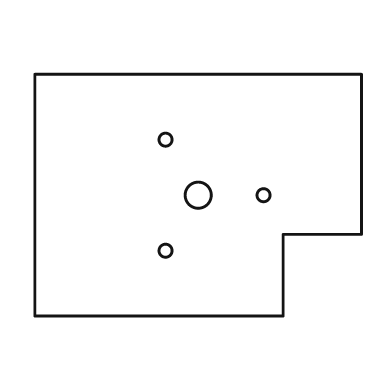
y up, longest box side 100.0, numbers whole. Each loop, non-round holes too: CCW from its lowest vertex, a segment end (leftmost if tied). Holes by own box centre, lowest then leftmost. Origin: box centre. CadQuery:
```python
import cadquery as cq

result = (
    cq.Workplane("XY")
    .moveTo(-50.0, -37.0)
    .lineTo(26.0, -37.0)
    .lineTo(26.0, -12.0)
    .lineTo(50.0, -12.0)
    .lineTo(50.0, 37.0)
    .lineTo(-50.0, 37.0)
    .close()
    .moveTo(-10.0, -17.0)
    .circle(2.0)
    .moveTo(0.0, 0.0)
    .circle(4.0)
    .moveTo(20.0, 0.0)
    .circle(2.0)
    .moveTo(-10.0, 17.0)
    .circle(2.0)
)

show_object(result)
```